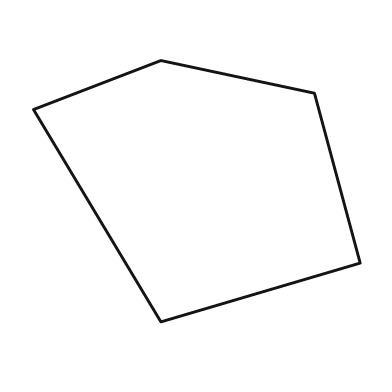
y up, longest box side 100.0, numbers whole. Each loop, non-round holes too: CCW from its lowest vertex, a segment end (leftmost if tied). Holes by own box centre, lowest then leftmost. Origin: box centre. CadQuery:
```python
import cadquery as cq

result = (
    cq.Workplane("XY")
    .moveTo(-11.0, -40.0)
    .lineTo(50.0, -22.0)
    .lineTo(36.0, 30.0)
    .lineTo(-11.0, 40.0)
    .lineTo(-50.0, 25.0)
    .close()
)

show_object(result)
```